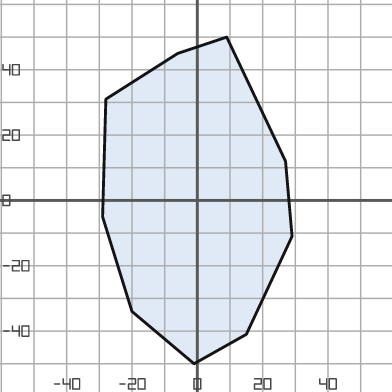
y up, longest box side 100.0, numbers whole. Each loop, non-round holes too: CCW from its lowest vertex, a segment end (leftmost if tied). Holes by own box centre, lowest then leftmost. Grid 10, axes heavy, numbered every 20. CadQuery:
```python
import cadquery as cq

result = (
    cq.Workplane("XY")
    .moveTo(-1.0, -50.0)
    .lineTo(15.0, -41.0)
    .lineTo(29.0, -11.0)
    .lineTo(27.0, 12.0)
    .lineTo(9.0, 50.0)
    .lineTo(-6.0, 45.0)
    .lineTo(-28.0, 31.0)
    .lineTo(-29.0, -5.0)
    .lineTo(-20.0, -34.0)
    .close()
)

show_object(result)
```